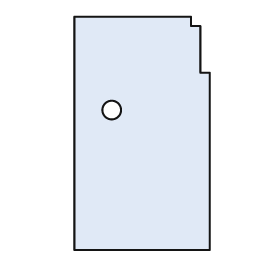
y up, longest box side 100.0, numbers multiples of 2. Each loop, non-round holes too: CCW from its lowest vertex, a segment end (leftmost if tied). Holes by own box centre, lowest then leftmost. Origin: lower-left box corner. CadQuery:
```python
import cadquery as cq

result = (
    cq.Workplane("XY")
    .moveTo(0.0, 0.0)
    .lineTo(58.0, 0.0)
    .lineTo(58.0, 76.0)
    .lineTo(54.0, 76.0)
    .lineTo(54.0, 96.0)
    .lineTo(50.0, 96.0)
    .lineTo(50.0, 100.0)
    .lineTo(0.0, 100.0)
    .close()
    .moveTo(16.0, 60.0)
    .circle(4.0)
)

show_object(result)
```